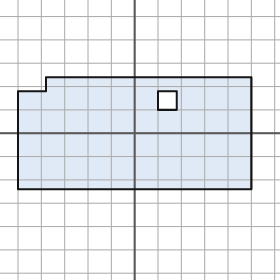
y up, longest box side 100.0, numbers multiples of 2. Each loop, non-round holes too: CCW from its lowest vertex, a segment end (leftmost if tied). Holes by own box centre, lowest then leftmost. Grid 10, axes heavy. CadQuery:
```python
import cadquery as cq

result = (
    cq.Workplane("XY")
    .moveTo(-50.0, -24.0)
    .lineTo(50.0, -24.0)
    .lineTo(50.0, 24.0)
    .lineTo(-38.0, 24.0)
    .lineTo(-38.0, 18.0)
    .lineTo(-50.0, 18.0)
    .close()
    .moveTo(10.0, 10.0)
    .lineTo(18.0, 10.0)
    .lineTo(18.0, 18.0)
    .lineTo(10.0, 18.0)
    .close()
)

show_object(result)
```